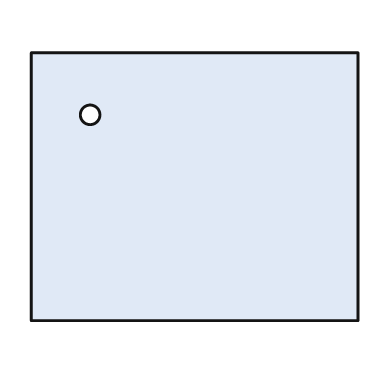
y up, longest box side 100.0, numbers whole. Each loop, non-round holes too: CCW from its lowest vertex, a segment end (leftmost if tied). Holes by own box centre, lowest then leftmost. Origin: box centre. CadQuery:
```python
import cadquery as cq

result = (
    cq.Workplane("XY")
    .moveTo(-50.0, -41.0)
    .lineTo(50.0, -41.0)
    .lineTo(50.0, 41.0)
    .lineTo(-50.0, 41.0)
    .close()
    .moveTo(-32.0, 22.0)
    .circle(3.0)
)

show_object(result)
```